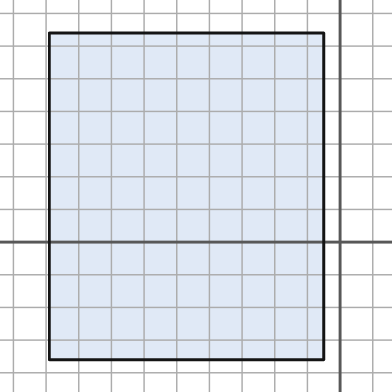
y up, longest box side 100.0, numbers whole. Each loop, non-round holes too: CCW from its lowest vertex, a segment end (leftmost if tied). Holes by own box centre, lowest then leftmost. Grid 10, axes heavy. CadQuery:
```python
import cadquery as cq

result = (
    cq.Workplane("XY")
    .moveTo(-89.0, -36.0)
    .lineTo(-5.0, -36.0)
    .lineTo(-5.0, 64.0)
    .lineTo(-89.0, 64.0)
    .close()
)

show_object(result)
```